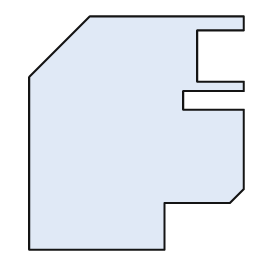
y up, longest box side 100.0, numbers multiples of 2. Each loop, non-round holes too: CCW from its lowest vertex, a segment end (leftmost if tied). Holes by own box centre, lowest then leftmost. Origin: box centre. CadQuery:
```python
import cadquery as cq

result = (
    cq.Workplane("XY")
    .moveTo(-46.0, -50.0)
    .lineTo(12.0, -50.0)
    .lineTo(12.0, -30.0)
    .lineTo(40.0, -30.0)
    .lineTo(46.0, -24.0)
    .lineTo(46.0, 10.0)
    .lineTo(20.0, 10.0)
    .lineTo(20.0, 18.0)
    .lineTo(46.0, 18.0)
    .lineTo(46.0, 22.0)
    .lineTo(26.0, 22.0)
    .lineTo(26.0, 44.0)
    .lineTo(46.0, 44.0)
    .lineTo(46.0, 50.0)
    .lineTo(-20.0, 50.0)
    .lineTo(-46.0, 24.0)
    .close()
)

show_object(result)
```